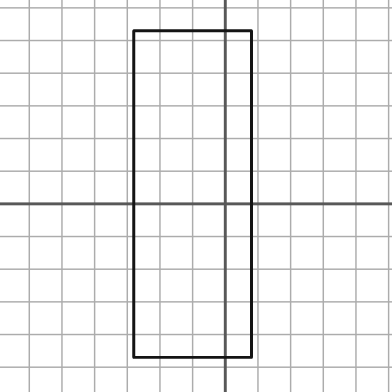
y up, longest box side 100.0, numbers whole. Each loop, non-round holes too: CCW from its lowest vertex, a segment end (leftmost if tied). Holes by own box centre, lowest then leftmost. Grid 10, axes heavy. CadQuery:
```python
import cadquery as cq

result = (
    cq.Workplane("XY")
    .moveTo(-28.0, -47.0)
    .lineTo(8.0, -47.0)
    .lineTo(8.0, 53.0)
    .lineTo(-28.0, 53.0)
    .close()
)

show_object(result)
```